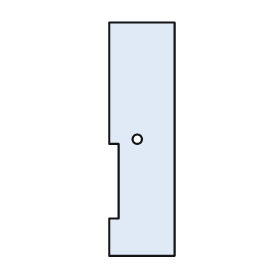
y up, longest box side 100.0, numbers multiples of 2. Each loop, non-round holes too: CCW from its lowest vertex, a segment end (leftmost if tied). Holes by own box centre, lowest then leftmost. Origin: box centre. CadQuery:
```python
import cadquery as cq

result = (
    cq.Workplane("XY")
    .moveTo(-14.0, -50.0)
    .lineTo(14.0, -50.0)
    .lineTo(14.0, 50.0)
    .lineTo(-14.0, 50.0)
    .lineTo(-14.0, -2.0)
    .lineTo(-10.0, -2.0)
    .lineTo(-10.0, -34.0)
    .lineTo(-14.0, -34.0)
    .close()
    .moveTo(-2.0, 0.0)
    .circle(2.0)
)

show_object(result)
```